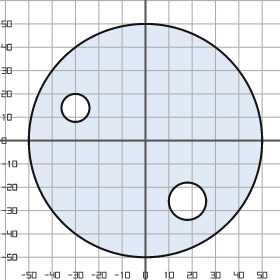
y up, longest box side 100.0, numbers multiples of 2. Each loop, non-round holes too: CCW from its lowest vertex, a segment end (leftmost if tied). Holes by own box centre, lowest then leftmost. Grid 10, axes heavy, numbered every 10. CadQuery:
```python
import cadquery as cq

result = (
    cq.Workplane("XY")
    .moveTo(0.0, 0.0)
    .circle(50.0)
    .moveTo(18.0, -26.0)
    .circle(8.0)
    .moveTo(-30.0, 14.0)
    .circle(6.0)
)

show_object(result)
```